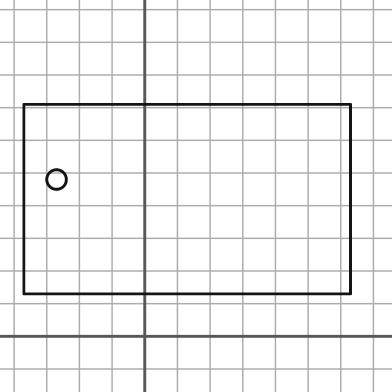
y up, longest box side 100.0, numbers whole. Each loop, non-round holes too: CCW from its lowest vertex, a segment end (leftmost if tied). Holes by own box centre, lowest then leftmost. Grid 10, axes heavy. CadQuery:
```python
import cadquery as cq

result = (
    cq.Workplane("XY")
    .moveTo(-37.0, 13.0)
    .lineTo(63.0, 13.0)
    .lineTo(63.0, 71.0)
    .lineTo(-37.0, 71.0)
    .close()
    .moveTo(-27.0, 48.0)
    .circle(3.0)
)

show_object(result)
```